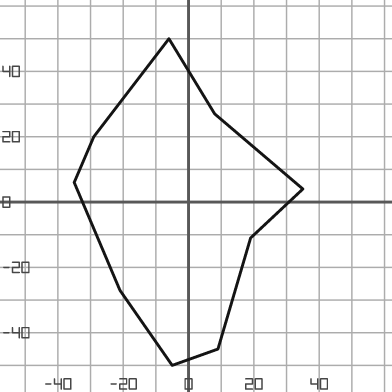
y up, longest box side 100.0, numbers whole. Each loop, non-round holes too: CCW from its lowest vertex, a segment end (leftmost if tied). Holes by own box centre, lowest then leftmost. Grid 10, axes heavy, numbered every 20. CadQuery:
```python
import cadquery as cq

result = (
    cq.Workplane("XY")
    .moveTo(-5.0, -50.0)
    .lineTo(9.0, -45.0)
    .lineTo(19.0, -11.0)
    .lineTo(35.0, 4.0)
    .lineTo(8.0, 27.0)
    .lineTo(-6.0, 50.0)
    .lineTo(-29.0, 20.0)
    .lineTo(-35.0, 6.0)
    .lineTo(-21.0, -27.0)
    .close()
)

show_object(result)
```